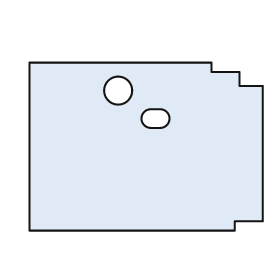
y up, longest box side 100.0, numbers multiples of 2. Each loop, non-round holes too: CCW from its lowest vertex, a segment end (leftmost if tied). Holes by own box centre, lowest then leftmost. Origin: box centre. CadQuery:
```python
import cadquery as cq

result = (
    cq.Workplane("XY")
    .moveTo(-50.0, -36.0)
    .lineTo(38.0, -36.0)
    .lineTo(38.0, -32.0)
    .lineTo(50.0, -32.0)
    .lineTo(50.0, 26.0)
    .lineTo(40.0, 26.0)
    .lineTo(40.0, 32.0)
    .lineTo(28.0, 32.0)
    .lineTo(28.0, 36.0)
    .lineTo(-50.0, 36.0)
    .close()
    .moveTo(2.0, 8.0)
    .lineTo(6.0, 8.0)
    .threePointArc((10.0, 12.0), (6.0, 16.0))
    .lineTo(2.0, 16.0)
    .threePointArc((-2.0, 12.0), (2.0, 8.0))
    .close()
    .moveTo(-12.0, 24.0)
    .circle(6.0)
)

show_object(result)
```